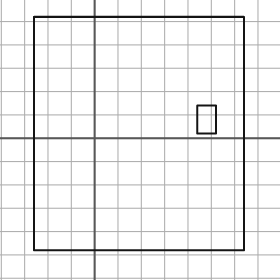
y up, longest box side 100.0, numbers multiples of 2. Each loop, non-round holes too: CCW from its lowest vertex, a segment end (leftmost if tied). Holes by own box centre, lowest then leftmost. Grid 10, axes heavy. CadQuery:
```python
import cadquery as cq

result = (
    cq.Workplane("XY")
    .moveTo(-26.0, -48.0)
    .lineTo(64.0, -48.0)
    .lineTo(64.0, 52.0)
    .lineTo(-26.0, 52.0)
    .close()
    .moveTo(44.0, 2.0)
    .lineTo(52.0, 2.0)
    .lineTo(52.0, 14.0)
    .lineTo(44.0, 14.0)
    .close()
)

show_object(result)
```